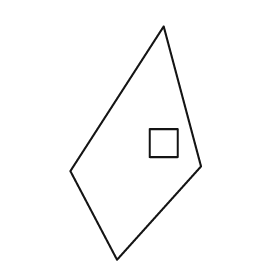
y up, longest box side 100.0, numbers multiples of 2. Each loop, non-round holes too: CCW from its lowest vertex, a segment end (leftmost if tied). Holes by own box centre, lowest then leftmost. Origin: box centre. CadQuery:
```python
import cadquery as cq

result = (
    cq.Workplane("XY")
    .moveTo(-8.0, -50.0)
    .lineTo(28.0, -10.0)
    .lineTo(12.0, 50.0)
    .lineTo(-28.0, -12.0)
    .close()
    .moveTo(6.0, -6.0)
    .lineTo(18.0, -6.0)
    .lineTo(18.0, 6.0)
    .lineTo(6.0, 6.0)
    .close()
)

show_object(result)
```